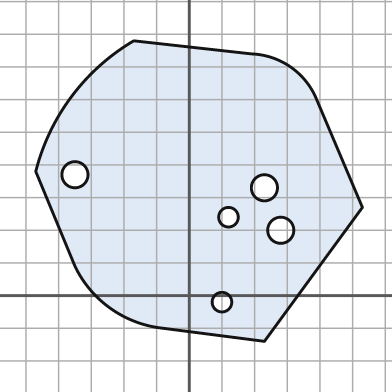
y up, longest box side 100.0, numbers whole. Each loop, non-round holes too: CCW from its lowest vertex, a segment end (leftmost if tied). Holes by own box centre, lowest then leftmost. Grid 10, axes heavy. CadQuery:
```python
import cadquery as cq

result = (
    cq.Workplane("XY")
    .moveTo(23.0, -14.0)
    .lineTo(53.0, 27.0)
    .lineTo(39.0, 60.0)
    .threePointArc((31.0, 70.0), (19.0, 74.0))
    .lineTo(-17.0, 78.0)
    .threePointArc((-36.0, 61.0), (-47.0, 38.0))
    .lineTo(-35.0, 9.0)
    .threePointArc((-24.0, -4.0), (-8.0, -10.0))
    .close()
    .moveTo(10.0, -2.0)
    .circle(3.0)
    .moveTo(28.0, 20.0)
    .circle(4.0)
    .moveTo(12.0, 24.0)
    .circle(3.0)
    .moveTo(23.0, 33.0)
    .circle(4.0)
    .moveTo(-35.0, 37.0)
    .circle(4.0)
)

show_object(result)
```